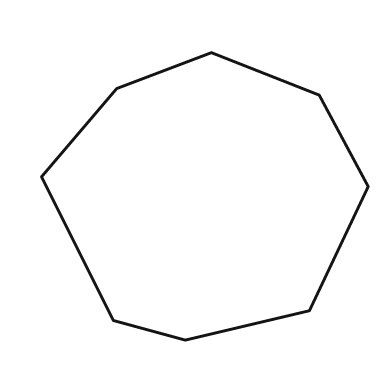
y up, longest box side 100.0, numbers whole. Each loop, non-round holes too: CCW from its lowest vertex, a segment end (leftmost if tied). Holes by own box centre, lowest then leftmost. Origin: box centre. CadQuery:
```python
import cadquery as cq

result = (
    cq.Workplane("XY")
    .moveTo(-6.0, -44.0)
    .lineTo(32.0, -35.0)
    .lineTo(50.0, 3.0)
    .lineTo(35.0, 31.0)
    .lineTo(2.0, 44.0)
    .lineTo(-27.0, 33.0)
    .lineTo(-50.0, 6.0)
    .lineTo(-28.0, -38.0)
    .close()
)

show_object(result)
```